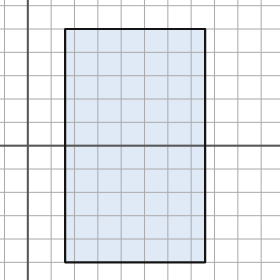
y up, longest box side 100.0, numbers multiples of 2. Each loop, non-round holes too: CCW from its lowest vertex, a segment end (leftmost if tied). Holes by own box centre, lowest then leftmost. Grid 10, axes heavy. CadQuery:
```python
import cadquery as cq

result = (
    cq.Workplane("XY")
    .moveTo(16.0, -50.0)
    .lineTo(76.0, -50.0)
    .lineTo(76.0, 50.0)
    .lineTo(16.0, 50.0)
    .close()
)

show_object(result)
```